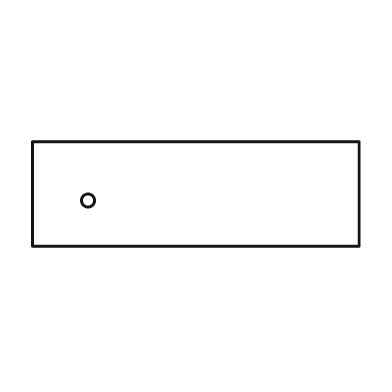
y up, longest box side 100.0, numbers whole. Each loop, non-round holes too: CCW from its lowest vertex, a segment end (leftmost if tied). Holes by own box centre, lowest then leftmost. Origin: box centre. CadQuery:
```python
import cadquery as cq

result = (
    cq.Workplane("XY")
    .moveTo(-50.0, -16.0)
    .lineTo(50.0, -16.0)
    .lineTo(50.0, 16.0)
    .lineTo(-50.0, 16.0)
    .close()
    .moveTo(-33.0, -2.0)
    .circle(2.0)
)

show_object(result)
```